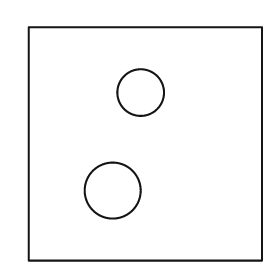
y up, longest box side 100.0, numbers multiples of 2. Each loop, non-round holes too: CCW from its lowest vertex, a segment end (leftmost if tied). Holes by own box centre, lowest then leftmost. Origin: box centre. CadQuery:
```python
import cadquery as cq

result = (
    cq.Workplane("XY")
    .moveTo(-50.0, -50.0)
    .lineTo(50.0, -50.0)
    .lineTo(50.0, 50.0)
    .lineTo(-50.0, 50.0)
    .close()
    .moveTo(-14.0, -20.0)
    .circle(12.0)
    .moveTo(-2.0, 22.0)
    .circle(10.0)
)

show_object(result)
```